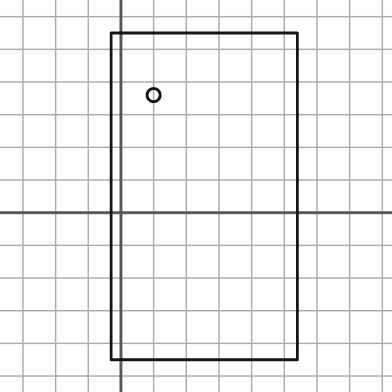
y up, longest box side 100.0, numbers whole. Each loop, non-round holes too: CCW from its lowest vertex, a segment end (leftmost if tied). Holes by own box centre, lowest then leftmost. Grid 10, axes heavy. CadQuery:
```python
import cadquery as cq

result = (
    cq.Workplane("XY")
    .moveTo(-3.0, -45.0)
    .lineTo(54.0, -45.0)
    .lineTo(54.0, 55.0)
    .lineTo(-3.0, 55.0)
    .close()
    .moveTo(10.0, 36.0)
    .circle(2.0)
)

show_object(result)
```